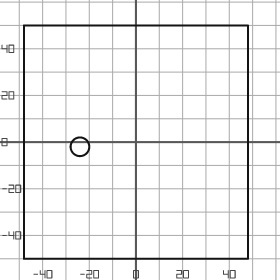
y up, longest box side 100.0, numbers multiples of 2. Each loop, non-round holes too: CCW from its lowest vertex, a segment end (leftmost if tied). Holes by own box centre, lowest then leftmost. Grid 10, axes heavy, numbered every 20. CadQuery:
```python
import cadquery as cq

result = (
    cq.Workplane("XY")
    .moveTo(-48.0, -50.0)
    .lineTo(48.0, -50.0)
    .lineTo(48.0, 50.0)
    .lineTo(-48.0, 50.0)
    .close()
    .moveTo(-24.0, -2.0)
    .circle(4.0)
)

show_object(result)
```